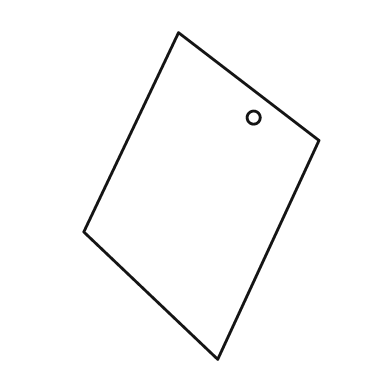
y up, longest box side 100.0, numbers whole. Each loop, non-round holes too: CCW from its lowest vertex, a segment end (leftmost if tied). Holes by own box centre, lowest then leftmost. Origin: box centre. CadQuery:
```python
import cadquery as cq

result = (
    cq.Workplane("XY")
    .moveTo(5.0, -50.0)
    .lineTo(36.0, 17.0)
    .lineTo(-7.0, 50.0)
    .lineTo(-36.0, -11.0)
    .close()
    .moveTo(16.0, 24.0)
    .circle(2.0)
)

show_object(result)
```